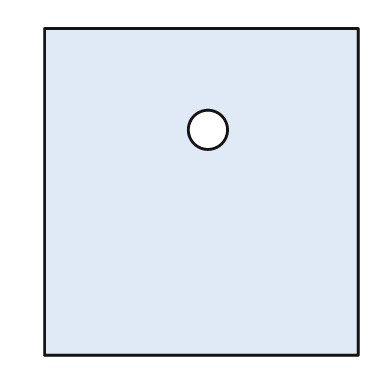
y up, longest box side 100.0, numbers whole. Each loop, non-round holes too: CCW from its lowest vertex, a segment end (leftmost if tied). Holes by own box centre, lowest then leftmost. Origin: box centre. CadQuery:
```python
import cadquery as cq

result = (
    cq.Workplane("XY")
    .moveTo(-48.0, -50.0)
    .lineTo(48.0, -50.0)
    .lineTo(48.0, 50.0)
    .lineTo(-48.0, 50.0)
    .close()
    .moveTo(2.0, 19.0)
    .circle(6.0)
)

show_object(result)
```